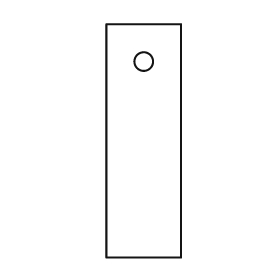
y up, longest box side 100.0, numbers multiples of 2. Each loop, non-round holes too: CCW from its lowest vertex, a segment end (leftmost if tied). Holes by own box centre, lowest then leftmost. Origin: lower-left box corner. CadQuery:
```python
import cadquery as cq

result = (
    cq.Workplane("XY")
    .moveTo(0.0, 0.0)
    .lineTo(32.0, 0.0)
    .lineTo(32.0, 100.0)
    .lineTo(0.0, 100.0)
    .close()
    .moveTo(16.0, 84.0)
    .circle(4.0)
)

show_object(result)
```